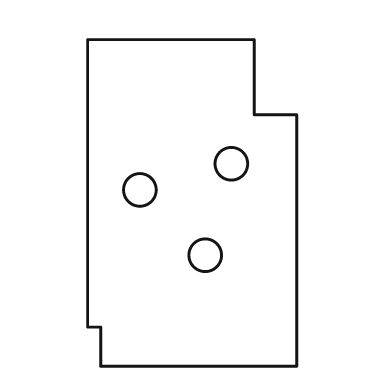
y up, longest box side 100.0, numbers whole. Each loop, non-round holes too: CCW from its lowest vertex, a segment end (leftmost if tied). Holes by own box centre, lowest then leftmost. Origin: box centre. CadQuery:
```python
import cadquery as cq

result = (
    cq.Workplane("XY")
    .moveTo(-28.0, -50.0)
    .lineTo(32.0, -50.0)
    .lineTo(32.0, 27.0)
    .lineTo(19.0, 27.0)
    .lineTo(19.0, 50.0)
    .lineTo(-32.0, 50.0)
    .lineTo(-32.0, -38.0)
    .lineTo(-28.0, -38.0)
    .close()
    .moveTo(4.0, -16.0)
    .circle(5.0)
    .moveTo(-16.0, 4.0)
    .circle(5.0)
    .moveTo(12.0, 12.0)
    .circle(5.0)
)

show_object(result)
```